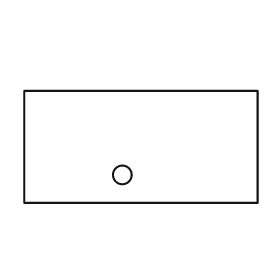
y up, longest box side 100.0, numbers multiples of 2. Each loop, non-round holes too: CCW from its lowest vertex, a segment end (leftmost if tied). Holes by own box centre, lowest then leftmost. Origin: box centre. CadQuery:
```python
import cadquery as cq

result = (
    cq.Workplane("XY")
    .moveTo(-50.0, -24.0)
    .lineTo(50.0, -24.0)
    .lineTo(50.0, 24.0)
    .lineTo(-50.0, 24.0)
    .close()
    .moveTo(-8.0, -12.0)
    .circle(4.0)
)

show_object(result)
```